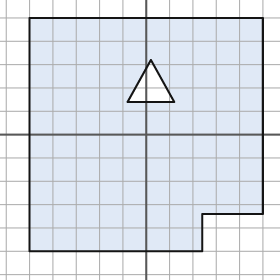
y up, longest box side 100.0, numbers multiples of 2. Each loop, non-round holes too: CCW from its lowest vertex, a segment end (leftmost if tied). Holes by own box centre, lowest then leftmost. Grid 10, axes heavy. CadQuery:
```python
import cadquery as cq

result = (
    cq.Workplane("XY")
    .moveTo(-50.0, -50.0)
    .lineTo(24.0, -50.0)
    .lineTo(24.0, -34.0)
    .lineTo(50.0, -34.0)
    .lineTo(50.0, 50.0)
    .lineTo(-50.0, 50.0)
    .close()
    .moveTo(-8.0, 14.0)
    .lineTo(12.0, 14.0)
    .lineTo(2.0, 32.0)
    .close()
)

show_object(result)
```